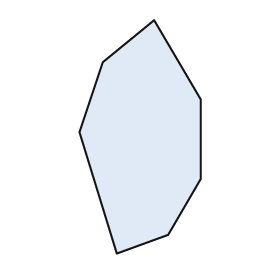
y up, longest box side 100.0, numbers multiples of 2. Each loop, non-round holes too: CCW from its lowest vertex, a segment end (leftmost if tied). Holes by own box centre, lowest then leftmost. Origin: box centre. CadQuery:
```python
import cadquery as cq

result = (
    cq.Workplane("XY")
    .moveTo(-10.0, -50.0)
    .lineTo(12.0, -42.0)
    .lineTo(26.0, -18.0)
    .lineTo(26.0, 16.0)
    .lineTo(6.0, 50.0)
    .lineTo(-16.0, 32.0)
    .lineTo(-26.0, 2.0)
    .close()
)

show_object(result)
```